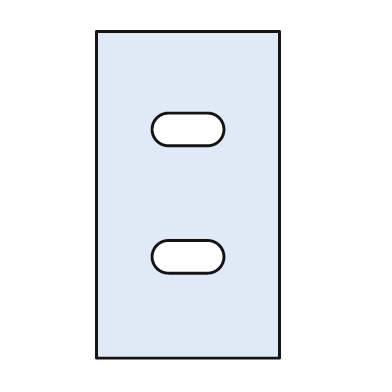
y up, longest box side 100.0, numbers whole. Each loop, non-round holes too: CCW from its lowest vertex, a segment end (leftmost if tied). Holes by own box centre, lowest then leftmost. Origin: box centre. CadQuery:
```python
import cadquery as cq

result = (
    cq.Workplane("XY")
    .moveTo(-28.0, -50.0)
    .lineTo(28.0, -50.0)
    .lineTo(28.0, 50.0)
    .lineTo(-28.0, 50.0)
    .close()
    .moveTo(-6.0, -24.0)
    .lineTo(6.0, -24.0)
    .threePointArc((11.0, -19.0), (6.0, -14.0))
    .lineTo(-6.0, -14.0)
    .threePointArc((-11.0, -19.0), (-6.0, -24.0))
    .close()
    .moveTo(-6.0, 15.0)
    .lineTo(6.0, 15.0)
    .threePointArc((11.0, 20.0), (6.0, 25.0))
    .lineTo(-6.0, 25.0)
    .threePointArc((-11.0, 20.0), (-6.0, 15.0))
    .close()
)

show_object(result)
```